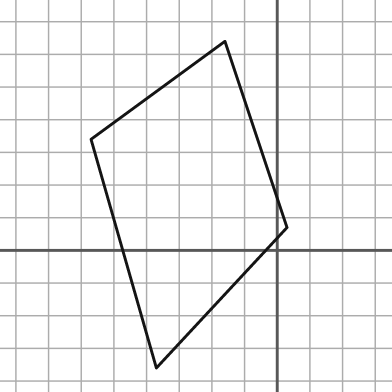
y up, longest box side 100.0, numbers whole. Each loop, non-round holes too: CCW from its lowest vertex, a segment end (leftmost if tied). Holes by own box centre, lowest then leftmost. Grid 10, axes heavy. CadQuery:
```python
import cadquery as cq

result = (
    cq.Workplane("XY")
    .moveTo(-37.0, -36.0)
    .lineTo(3.0, 7.0)
    .lineTo(-16.0, 64.0)
    .lineTo(-57.0, 34.0)
    .close()
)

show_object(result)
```